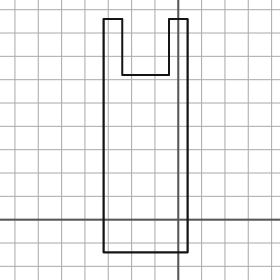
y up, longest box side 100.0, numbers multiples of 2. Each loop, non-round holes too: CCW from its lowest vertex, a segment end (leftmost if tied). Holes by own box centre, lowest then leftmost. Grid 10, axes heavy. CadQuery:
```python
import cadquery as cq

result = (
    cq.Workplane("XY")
    .moveTo(-32.0, -14.0)
    .lineTo(4.0, -14.0)
    .lineTo(4.0, 86.0)
    .lineTo(-4.0, 86.0)
    .lineTo(-4.0, 62.0)
    .lineTo(-24.0, 62.0)
    .lineTo(-24.0, 86.0)
    .lineTo(-32.0, 86.0)
    .close()
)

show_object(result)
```